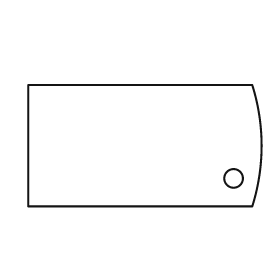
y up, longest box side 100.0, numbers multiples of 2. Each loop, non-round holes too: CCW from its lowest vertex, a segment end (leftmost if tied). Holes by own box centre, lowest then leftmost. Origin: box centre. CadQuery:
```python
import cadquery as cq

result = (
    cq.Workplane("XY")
    .moveTo(-50.0, -26.0)
    .lineTo(46.0, -26.0)
    .threePointArc((50.0, 0.0), (46.0, 26.0))
    .lineTo(-50.0, 26.0)
    .close()
    .moveTo(38.0, -14.0)
    .circle(4.0)
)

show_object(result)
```